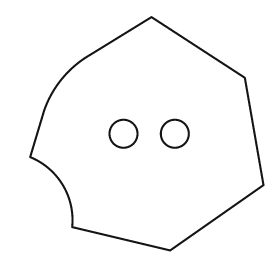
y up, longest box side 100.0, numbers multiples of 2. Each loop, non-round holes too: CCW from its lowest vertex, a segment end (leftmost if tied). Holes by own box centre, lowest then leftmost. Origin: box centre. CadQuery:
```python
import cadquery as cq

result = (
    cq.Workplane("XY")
    .moveTo(10.0, -50.0)
    .lineTo(50.0, -22.0)
    .lineTo(42.0, 24.0)
    .lineTo(2.0, 50.0)
    .lineTo(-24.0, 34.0)
    .threePointArc((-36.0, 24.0), (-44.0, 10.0))
    .lineTo(-50.0, -10.0)
    .threePointArc((-36.0, -22.0), (-32.0, -40.0))
    .close()
    .moveTo(-10.0, 0.0)
    .circle(6.0)
    .moveTo(12.0, 0.0)
    .circle(6.0)
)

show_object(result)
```